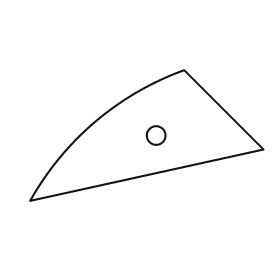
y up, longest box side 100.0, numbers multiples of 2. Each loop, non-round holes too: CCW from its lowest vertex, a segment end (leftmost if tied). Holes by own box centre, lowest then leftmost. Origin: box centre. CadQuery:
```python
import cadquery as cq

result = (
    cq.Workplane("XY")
    .moveTo(-50.0, -28.0)
    .lineTo(50.0, -6.0)
    .lineTo(16.0, 28.0)
    .threePointArc((-22.0, 6.0), (-50.0, -28.0))
    .close()
    .moveTo(4.0, 0.0)
    .circle(4.0)
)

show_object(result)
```